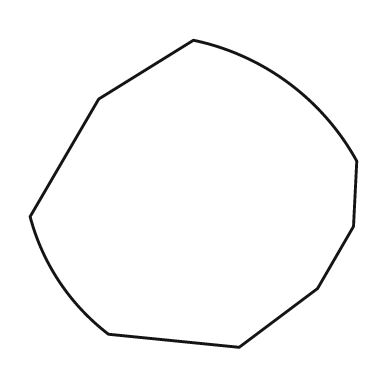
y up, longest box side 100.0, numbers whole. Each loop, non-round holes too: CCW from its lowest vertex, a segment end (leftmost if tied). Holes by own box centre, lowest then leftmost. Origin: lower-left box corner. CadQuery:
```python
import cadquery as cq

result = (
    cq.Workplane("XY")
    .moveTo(64.0, 0.0)
    .lineTo(88.0, 18.0)
    .lineTo(99.0, 37.0)
    .lineTo(100.0, 57.0)
    .threePointArc((79.0, 81.0), (50.0, 94.0))
    .lineTo(21.0, 76.0)
    .lineTo(0.0, 40.0)
    .threePointArc((9.0, 20.0), (24.0, 4.0))
    .close()
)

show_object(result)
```